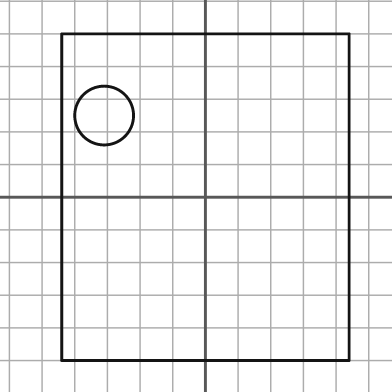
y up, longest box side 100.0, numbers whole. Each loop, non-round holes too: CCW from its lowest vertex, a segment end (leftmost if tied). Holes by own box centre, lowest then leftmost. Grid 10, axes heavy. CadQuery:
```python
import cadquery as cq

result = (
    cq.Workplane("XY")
    .moveTo(-44.0, -50.0)
    .lineTo(44.0, -50.0)
    .lineTo(44.0, 50.0)
    .lineTo(-44.0, 50.0)
    .close()
    .moveTo(-31.0, 25.0)
    .circle(9.0)
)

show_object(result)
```